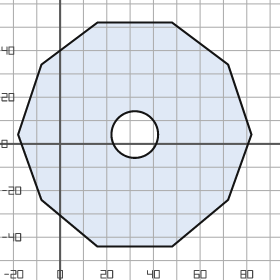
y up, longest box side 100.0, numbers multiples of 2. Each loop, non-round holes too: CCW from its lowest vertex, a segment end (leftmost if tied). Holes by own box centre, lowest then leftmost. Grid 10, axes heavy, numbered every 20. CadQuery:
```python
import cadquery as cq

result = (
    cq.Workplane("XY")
    .moveTo(16.0, -44.0)
    .lineTo(48.0, -44.0)
    .lineTo(72.0, -24.0)
    .lineTo(82.0, 4.0)
    .lineTo(72.0, 34.0)
    .lineTo(48.0, 52.0)
    .lineTo(16.0, 52.0)
    .lineTo(-8.0, 34.0)
    .lineTo(-18.0, 4.0)
    .lineTo(-8.0, -24.0)
    .close()
    .moveTo(32.0, 4.0)
    .circle(10.0)
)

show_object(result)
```